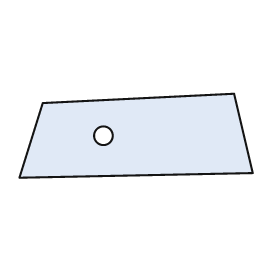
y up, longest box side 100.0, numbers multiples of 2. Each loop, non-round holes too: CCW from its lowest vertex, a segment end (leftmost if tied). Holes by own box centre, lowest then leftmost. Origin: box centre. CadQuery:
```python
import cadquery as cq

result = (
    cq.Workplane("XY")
    .moveTo(-50.0, -18.0)
    .lineTo(50.0, -16.0)
    .lineTo(42.0, 18.0)
    .lineTo(-40.0, 14.0)
    .close()
    .moveTo(-14.0, 0.0)
    .circle(4.0)
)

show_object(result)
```